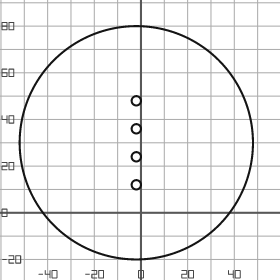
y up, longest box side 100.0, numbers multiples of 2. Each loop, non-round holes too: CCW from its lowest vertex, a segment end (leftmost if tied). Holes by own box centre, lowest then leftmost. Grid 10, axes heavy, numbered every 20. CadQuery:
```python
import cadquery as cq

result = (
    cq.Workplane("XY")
    .moveTo(-2.0, 30.0)
    .circle(50.0)
    .moveTo(-2.0, 12.0)
    .circle(2.0)
    .moveTo(-2.0, 24.0)
    .circle(2.0)
    .moveTo(-2.0, 36.0)
    .circle(2.0)
    .moveTo(-2.0, 48.0)
    .circle(2.0)
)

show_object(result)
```